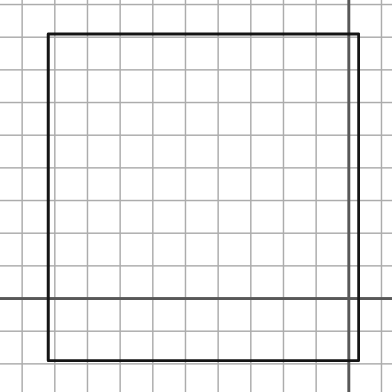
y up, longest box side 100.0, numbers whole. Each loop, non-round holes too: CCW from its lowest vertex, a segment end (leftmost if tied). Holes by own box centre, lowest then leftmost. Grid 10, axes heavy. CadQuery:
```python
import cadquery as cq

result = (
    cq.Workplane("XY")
    .moveTo(-92.0, -19.0)
    .lineTo(3.0, -19.0)
    .lineTo(3.0, 81.0)
    .lineTo(-92.0, 81.0)
    .close()
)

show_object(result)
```